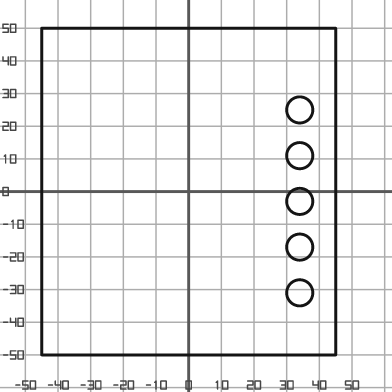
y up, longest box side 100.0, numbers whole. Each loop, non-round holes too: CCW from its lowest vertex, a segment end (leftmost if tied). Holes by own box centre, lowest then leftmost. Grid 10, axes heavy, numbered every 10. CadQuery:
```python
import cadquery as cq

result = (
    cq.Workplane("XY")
    .moveTo(-45.0, -50.0)
    .lineTo(45.0, -50.0)
    .lineTo(45.0, 50.0)
    .lineTo(-45.0, 50.0)
    .close()
    .moveTo(34.0, -31.0)
    .circle(4.0)
    .moveTo(34.0, -17.0)
    .circle(4.0)
    .moveTo(34.0, -3.0)
    .circle(4.0)
    .moveTo(34.0, 11.0)
    .circle(4.0)
    .moveTo(34.0, 25.0)
    .circle(4.0)
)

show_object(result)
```